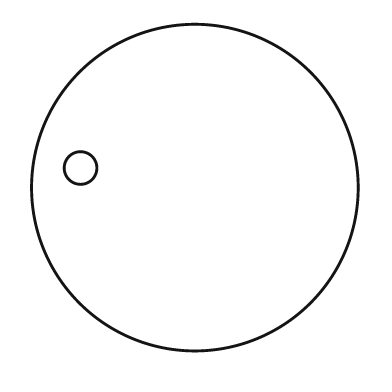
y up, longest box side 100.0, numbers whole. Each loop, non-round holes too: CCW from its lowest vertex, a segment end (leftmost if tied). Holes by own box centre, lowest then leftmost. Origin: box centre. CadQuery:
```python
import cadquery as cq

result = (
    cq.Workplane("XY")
    .moveTo(0.0, 0.0)
    .circle(50.0)
    .moveTo(-35.0, 6.0)
    .circle(5.0)
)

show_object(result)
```